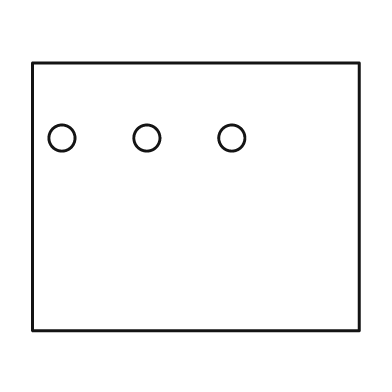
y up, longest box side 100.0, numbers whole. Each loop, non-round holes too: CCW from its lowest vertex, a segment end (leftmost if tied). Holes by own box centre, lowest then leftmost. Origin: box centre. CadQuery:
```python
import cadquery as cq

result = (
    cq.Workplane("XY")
    .moveTo(-50.0, -41.0)
    .lineTo(50.0, -41.0)
    .lineTo(50.0, 41.0)
    .lineTo(-50.0, 41.0)
    .close()
    .moveTo(-41.0, 18.0)
    .circle(4.0)
    .moveTo(-15.0, 18.0)
    .circle(4.0)
    .moveTo(11.0, 18.0)
    .circle(4.0)
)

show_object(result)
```